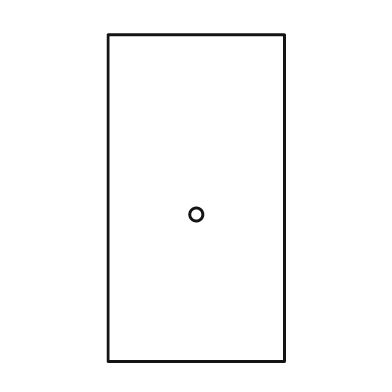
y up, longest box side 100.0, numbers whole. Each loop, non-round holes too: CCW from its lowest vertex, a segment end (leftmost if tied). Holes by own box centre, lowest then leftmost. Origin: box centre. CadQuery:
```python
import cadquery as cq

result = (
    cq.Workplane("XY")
    .moveTo(-27.0, -50.0)
    .lineTo(27.0, -50.0)
    .lineTo(27.0, 50.0)
    .lineTo(-27.0, 50.0)
    .close()
    .moveTo(0.0, -5.0)
    .circle(2.0)
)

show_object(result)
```